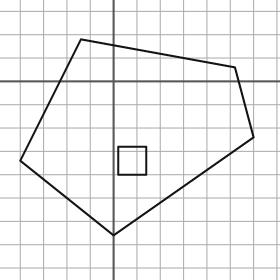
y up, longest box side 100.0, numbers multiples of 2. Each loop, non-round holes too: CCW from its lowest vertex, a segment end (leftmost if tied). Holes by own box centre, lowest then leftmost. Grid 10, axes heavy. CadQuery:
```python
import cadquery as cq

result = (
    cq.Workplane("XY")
    .moveTo(0.0, -66.0)
    .lineTo(60.0, -24.0)
    .lineTo(52.0, 6.0)
    .lineTo(-14.0, 18.0)
    .lineTo(-40.0, -34.0)
    .close()
    .moveTo(2.0, -40.0)
    .lineTo(14.0, -40.0)
    .lineTo(14.0, -28.0)
    .lineTo(2.0, -28.0)
    .close()
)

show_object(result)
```